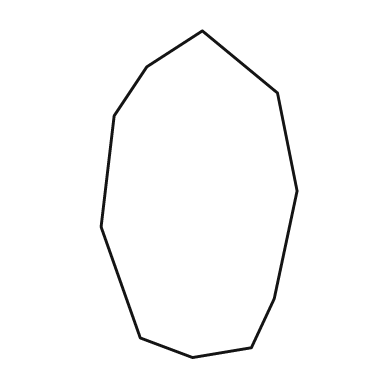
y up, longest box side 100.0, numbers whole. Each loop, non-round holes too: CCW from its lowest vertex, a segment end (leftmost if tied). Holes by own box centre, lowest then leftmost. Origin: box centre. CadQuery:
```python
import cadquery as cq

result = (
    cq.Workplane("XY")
    .moveTo(-2.0, -50.0)
    .lineTo(16.0, -47.0)
    .lineTo(23.0, -32.0)
    .lineTo(30.0, 1.0)
    .lineTo(24.0, 31.0)
    .lineTo(1.0, 50.0)
    .lineTo(-16.0, 39.0)
    .lineTo(-26.0, 24.0)
    .lineTo(-30.0, -10.0)
    .lineTo(-18.0, -44.0)
    .close()
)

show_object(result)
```